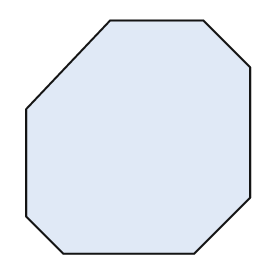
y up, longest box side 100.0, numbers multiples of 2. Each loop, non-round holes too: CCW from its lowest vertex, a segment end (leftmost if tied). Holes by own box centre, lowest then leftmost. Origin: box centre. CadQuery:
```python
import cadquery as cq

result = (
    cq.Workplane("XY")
    .moveTo(-32.0, -50.0)
    .lineTo(24.0, -50.0)
    .lineTo(48.0, -26.0)
    .lineTo(48.0, 30.0)
    .lineTo(28.0, 50.0)
    .lineTo(-12.0, 50.0)
    .lineTo(-48.0, 12.0)
    .lineTo(-48.0, -34.0)
    .close()
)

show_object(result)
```